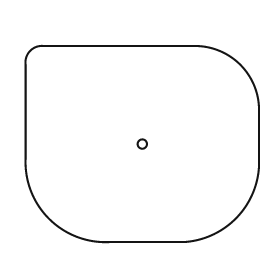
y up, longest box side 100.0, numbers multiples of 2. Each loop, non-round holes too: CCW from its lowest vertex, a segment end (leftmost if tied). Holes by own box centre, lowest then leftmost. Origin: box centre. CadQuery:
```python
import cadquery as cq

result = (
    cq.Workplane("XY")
    .moveTo(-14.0, -42.0)
    .lineTo(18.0, -42.0)
    .threePointArc((40.0, -32.0), (50.0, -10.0))
    .lineTo(50.0, 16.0)
    .threePointArc((42.0, 34.0), (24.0, 42.0))
    .lineTo(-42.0, 42.0)
    .threePointArc((-48.0, 40.0), (-50.0, 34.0))
    .lineTo(-50.0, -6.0)
    .threePointArc((-40.0, -32.0), (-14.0, -42.0))
    .close()
    .moveTo(0.0, 0.0)
    .circle(2.0)
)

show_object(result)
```